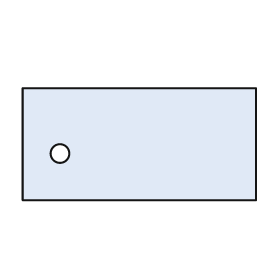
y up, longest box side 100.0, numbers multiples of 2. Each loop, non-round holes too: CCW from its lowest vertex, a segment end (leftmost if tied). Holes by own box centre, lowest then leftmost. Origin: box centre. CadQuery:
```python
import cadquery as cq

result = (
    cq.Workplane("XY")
    .moveTo(-50.0, -24.0)
    .lineTo(50.0, -24.0)
    .lineTo(50.0, 24.0)
    .lineTo(-50.0, 24.0)
    .close()
    .moveTo(-34.0, -4.0)
    .circle(4.0)
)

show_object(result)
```